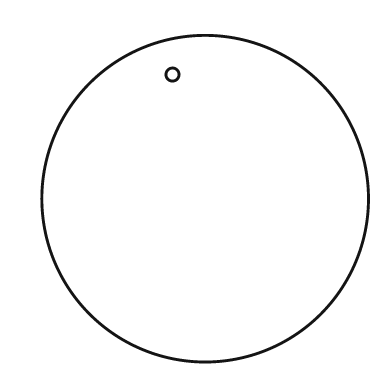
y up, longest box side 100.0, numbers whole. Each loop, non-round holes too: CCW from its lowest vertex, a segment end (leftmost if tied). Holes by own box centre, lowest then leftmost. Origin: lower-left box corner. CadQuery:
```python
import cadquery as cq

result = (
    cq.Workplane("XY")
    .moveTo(50.0, 50.0)
    .circle(50.0)
    .moveTo(40.0, 88.0)
    .circle(2.0)
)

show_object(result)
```